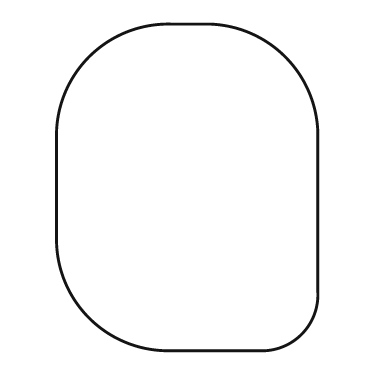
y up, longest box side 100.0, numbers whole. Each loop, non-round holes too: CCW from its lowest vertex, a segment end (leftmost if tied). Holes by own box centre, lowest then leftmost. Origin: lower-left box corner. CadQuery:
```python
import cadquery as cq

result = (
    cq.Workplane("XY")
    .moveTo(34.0, 0.0)
    .lineTo(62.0, 0.0)
    .threePointArc((75.0, 5.0), (80.0, 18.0))
    .lineTo(80.0, 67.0)
    .threePointArc((70.0, 90.0), (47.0, 100.0))
    .lineTo(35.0, 100.0)
    .threePointArc((10.0, 90.0), (0.0, 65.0))
    .lineTo(0.0, 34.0)
    .threePointArc((10.0, 10.0), (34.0, 0.0))
    .close()
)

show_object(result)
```